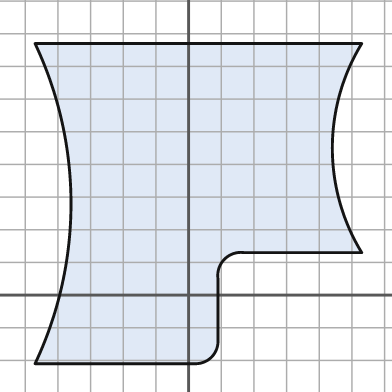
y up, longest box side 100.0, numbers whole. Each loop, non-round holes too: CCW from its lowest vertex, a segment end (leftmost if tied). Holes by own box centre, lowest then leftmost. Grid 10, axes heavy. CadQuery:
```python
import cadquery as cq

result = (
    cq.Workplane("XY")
    .moveTo(-47.0, -21.0)
    .lineTo(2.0, -21.0)
    .threePointArc((7.0, -19.0), (9.0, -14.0))
    .lineTo(9.0, 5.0)
    .threePointArc((11.0, 11.0), (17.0, 13.0))
    .lineTo(53.0, 13.0)
    .threePointArc((44.0, 45.0), (53.0, 77.0))
    .lineTo(-47.0, 77.0)
    .threePointArc((-36.0, 28.0), (-47.0, -21.0))
    .close()
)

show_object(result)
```